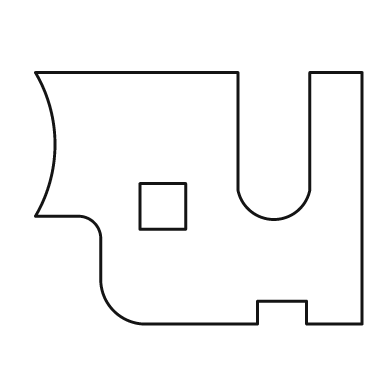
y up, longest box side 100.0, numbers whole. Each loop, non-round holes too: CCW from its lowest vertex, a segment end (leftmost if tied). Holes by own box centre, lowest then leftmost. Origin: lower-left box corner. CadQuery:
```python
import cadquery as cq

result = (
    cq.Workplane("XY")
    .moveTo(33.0, 0.0)
    .lineTo(68.0, 0.0)
    .lineTo(68.0, 7.0)
    .lineTo(83.0, 7.0)
    .lineTo(83.0, 0.0)
    .lineTo(100.0, 0.0)
    .lineTo(100.0, 77.0)
    .lineTo(84.0, 77.0)
    .lineTo(84.0, 41.0)
    .threePointArc((73.0, 32.0), (62.0, 41.0))
    .lineTo(62.0, 77.0)
    .lineTo(0.0, 77.0)
    .threePointArc((6.0, 55.0), (0.0, 33.0))
    .lineTo(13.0, 33.0)
    .threePointArc((18.0, 31.0), (20.0, 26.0))
    .lineTo(20.0, 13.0)
    .threePointArc((24.0, 4.0), (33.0, 0.0))
    .close()
    .moveTo(32.0, 29.0)
    .lineTo(46.0, 29.0)
    .lineTo(46.0, 43.0)
    .lineTo(32.0, 43.0)
    .close()
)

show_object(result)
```